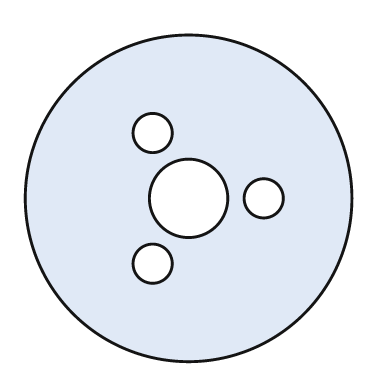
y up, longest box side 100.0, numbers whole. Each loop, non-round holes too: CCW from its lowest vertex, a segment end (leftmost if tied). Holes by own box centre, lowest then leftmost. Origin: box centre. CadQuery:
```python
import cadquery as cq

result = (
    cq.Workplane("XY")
    .moveTo(0.0, 0.0)
    .circle(50.0)
    .moveTo(-11.0, -20.0)
    .circle(6.0)
    .moveTo(0.0, 0.0)
    .circle(12.0)
    .moveTo(23.0, 0.0)
    .circle(6.0)
    .moveTo(-11.0, 20.0)
    .circle(6.0)
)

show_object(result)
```